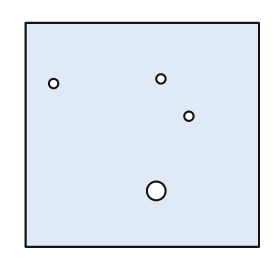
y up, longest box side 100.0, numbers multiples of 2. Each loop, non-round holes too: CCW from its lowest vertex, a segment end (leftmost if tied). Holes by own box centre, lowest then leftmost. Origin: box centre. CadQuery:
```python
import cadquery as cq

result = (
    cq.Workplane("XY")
    .moveTo(-50.0, -48.0)
    .lineTo(50.0, -48.0)
    .lineTo(50.0, 48.0)
    .lineTo(-50.0, 48.0)
    .close()
    .moveTo(6.0, -24.0)
    .circle(4.0)
    .moveTo(20.0, 8.0)
    .circle(2.0)
    .moveTo(-38.0, 22.0)
    .circle(2.0)
    .moveTo(8.0, 24.0)
    .circle(2.0)
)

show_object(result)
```